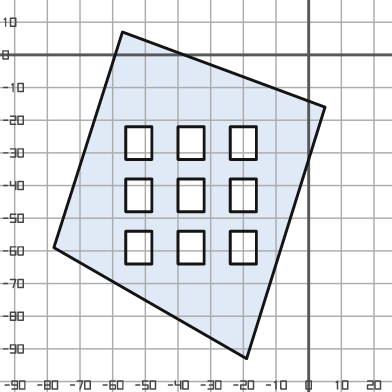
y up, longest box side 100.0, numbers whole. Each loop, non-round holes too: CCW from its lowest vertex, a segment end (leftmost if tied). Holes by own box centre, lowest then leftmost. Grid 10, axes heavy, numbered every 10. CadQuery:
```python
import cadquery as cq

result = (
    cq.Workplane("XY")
    .moveTo(-19.0, -93.0)
    .lineTo(5.0, -16.0)
    .lineTo(-57.0, 7.0)
    .lineTo(-78.0, -59.0)
    .close()
    .moveTo(-56.0, -64.0)
    .lineTo(-48.0, -64.0)
    .lineTo(-48.0, -54.0)
    .lineTo(-56.0, -54.0)
    .close()
    .moveTo(-40.0, -64.0)
    .lineTo(-32.0, -64.0)
    .lineTo(-32.0, -54.0)
    .lineTo(-40.0, -54.0)
    .close()
    .moveTo(-24.0, -64.0)
    .lineTo(-16.0, -64.0)
    .lineTo(-16.0, -54.0)
    .lineTo(-24.0, -54.0)
    .close()
    .moveTo(-56.0, -48.0)
    .lineTo(-48.0, -48.0)
    .lineTo(-48.0, -38.0)
    .lineTo(-56.0, -38.0)
    .close()
    .moveTo(-40.0, -48.0)
    .lineTo(-32.0, -48.0)
    .lineTo(-32.0, -38.0)
    .lineTo(-40.0, -38.0)
    .close()
    .moveTo(-24.0, -48.0)
    .lineTo(-16.0, -48.0)
    .lineTo(-16.0, -38.0)
    .lineTo(-24.0, -38.0)
    .close()
    .moveTo(-56.0, -32.0)
    .lineTo(-48.0, -32.0)
    .lineTo(-48.0, -22.0)
    .lineTo(-56.0, -22.0)
    .close()
    .moveTo(-40.0, -32.0)
    .lineTo(-32.0, -32.0)
    .lineTo(-32.0, -22.0)
    .lineTo(-40.0, -22.0)
    .close()
    .moveTo(-24.0, -32.0)
    .lineTo(-16.0, -32.0)
    .lineTo(-16.0, -22.0)
    .lineTo(-24.0, -22.0)
    .close()
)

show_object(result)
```